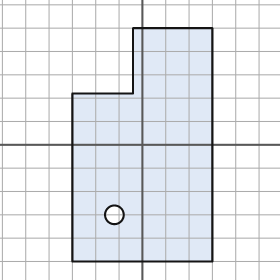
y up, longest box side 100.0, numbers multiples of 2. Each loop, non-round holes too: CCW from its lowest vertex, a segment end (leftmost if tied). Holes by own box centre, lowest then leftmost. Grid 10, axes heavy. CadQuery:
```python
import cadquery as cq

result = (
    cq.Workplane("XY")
    .moveTo(-30.0, -50.0)
    .lineTo(30.0, -50.0)
    .lineTo(30.0, 50.0)
    .lineTo(-4.0, 50.0)
    .lineTo(-4.0, 22.0)
    .lineTo(-30.0, 22.0)
    .close()
    .moveTo(-12.0, -30.0)
    .circle(4.0)
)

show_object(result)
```